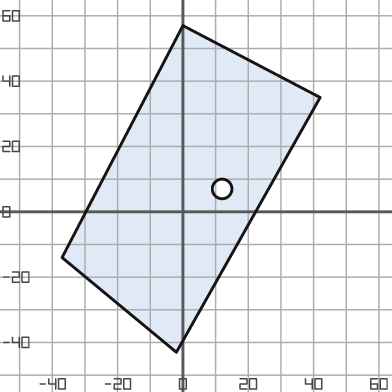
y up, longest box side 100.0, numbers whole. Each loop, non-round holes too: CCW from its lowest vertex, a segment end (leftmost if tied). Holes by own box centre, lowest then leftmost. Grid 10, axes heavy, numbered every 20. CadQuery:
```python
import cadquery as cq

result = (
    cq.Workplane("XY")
    .moveTo(-2.0, -43.0)
    .lineTo(42.0, 35.0)
    .lineTo(0.0, 57.0)
    .lineTo(-37.0, -14.0)
    .close()
    .moveTo(12.0, 7.0)
    .circle(3.0)
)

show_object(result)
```